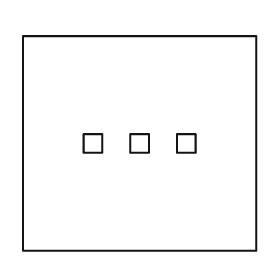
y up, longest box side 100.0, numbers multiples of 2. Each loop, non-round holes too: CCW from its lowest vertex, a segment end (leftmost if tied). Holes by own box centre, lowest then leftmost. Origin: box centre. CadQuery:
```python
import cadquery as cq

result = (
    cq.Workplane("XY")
    .moveTo(-50.0, -46.0)
    .lineTo(50.0, -46.0)
    .lineTo(50.0, 46.0)
    .lineTo(-50.0, 46.0)
    .close()
    .moveTo(-24.0, -4.0)
    .lineTo(-16.0, -4.0)
    .lineTo(-16.0, 4.0)
    .lineTo(-24.0, 4.0)
    .close()
    .moveTo(-4.0, -4.0)
    .lineTo(4.0, -4.0)
    .lineTo(4.0, 4.0)
    .lineTo(-4.0, 4.0)
    .close()
    .moveTo(16.0, -4.0)
    .lineTo(24.0, -4.0)
    .lineTo(24.0, 4.0)
    .lineTo(16.0, 4.0)
    .close()
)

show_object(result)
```